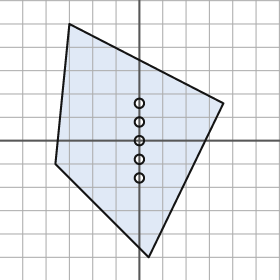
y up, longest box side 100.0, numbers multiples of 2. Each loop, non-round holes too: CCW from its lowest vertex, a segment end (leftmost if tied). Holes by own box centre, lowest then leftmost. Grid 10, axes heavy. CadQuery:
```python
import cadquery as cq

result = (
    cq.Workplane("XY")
    .moveTo(4.0, -50.0)
    .lineTo(36.0, 16.0)
    .lineTo(-30.0, 50.0)
    .lineTo(-36.0, -10.0)
    .close()
    .moveTo(0.0, -16.0)
    .circle(2.0)
    .moveTo(0.0, -8.0)
    .circle(2.0)
    .moveTo(0.0, 0.0)
    .circle(2.0)
    .moveTo(0.0, 8.0)
    .circle(2.0)
    .moveTo(0.0, 16.0)
    .circle(2.0)
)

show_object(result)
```